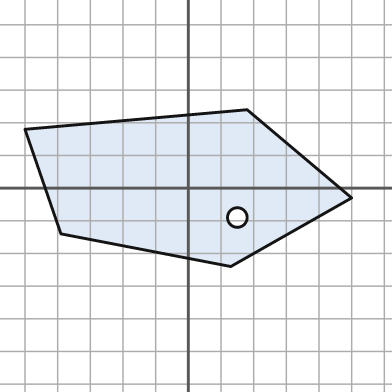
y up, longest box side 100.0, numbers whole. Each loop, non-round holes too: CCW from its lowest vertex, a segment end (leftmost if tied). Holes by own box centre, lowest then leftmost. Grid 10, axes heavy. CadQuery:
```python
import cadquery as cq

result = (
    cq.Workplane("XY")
    .moveTo(13.0, -24.0)
    .lineTo(50.0, -3.0)
    .lineTo(18.0, 24.0)
    .lineTo(-50.0, 18.0)
    .lineTo(-39.0, -14.0)
    .close()
    .moveTo(15.0, -9.0)
    .circle(3.0)
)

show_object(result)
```